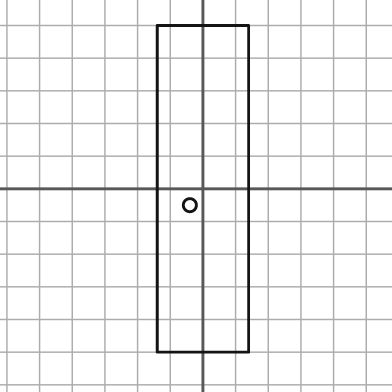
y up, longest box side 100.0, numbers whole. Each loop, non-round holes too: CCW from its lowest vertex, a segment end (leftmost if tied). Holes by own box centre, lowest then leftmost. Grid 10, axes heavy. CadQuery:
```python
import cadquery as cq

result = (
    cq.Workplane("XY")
    .moveTo(-14.0, -50.0)
    .lineTo(14.0, -50.0)
    .lineTo(14.0, 50.0)
    .lineTo(-14.0, 50.0)
    .close()
    .moveTo(-4.0, -5.0)
    .circle(2.0)
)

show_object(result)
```